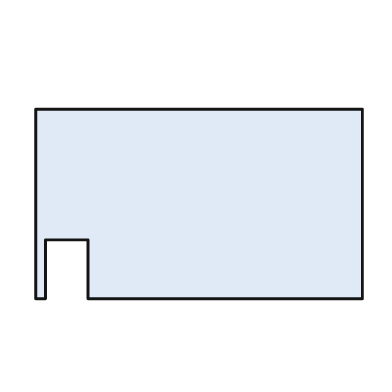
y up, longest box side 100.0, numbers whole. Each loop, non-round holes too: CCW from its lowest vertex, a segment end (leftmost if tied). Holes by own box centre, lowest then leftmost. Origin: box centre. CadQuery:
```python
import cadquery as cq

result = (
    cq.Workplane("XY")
    .moveTo(-50.0, -29.0)
    .lineTo(-47.0, -29.0)
    .lineTo(-47.0, -11.0)
    .lineTo(-34.0, -11.0)
    .lineTo(-34.0, -29.0)
    .lineTo(50.0, -29.0)
    .lineTo(50.0, 29.0)
    .lineTo(-50.0, 29.0)
    .close()
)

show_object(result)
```